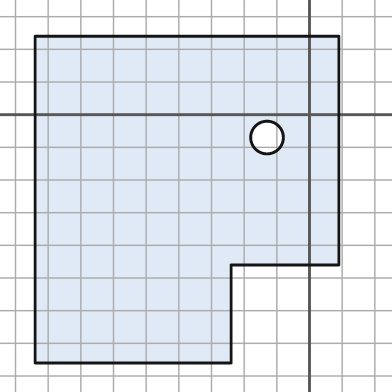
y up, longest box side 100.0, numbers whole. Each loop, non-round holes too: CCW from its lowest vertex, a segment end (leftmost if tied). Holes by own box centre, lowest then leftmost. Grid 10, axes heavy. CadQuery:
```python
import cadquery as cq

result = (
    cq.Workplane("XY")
    .moveTo(-84.0, -76.0)
    .lineTo(-24.0, -76.0)
    .lineTo(-24.0, -46.0)
    .lineTo(9.0, -46.0)
    .lineTo(9.0, 24.0)
    .lineTo(-84.0, 24.0)
    .close()
    .moveTo(-13.0, -7.0)
    .circle(5.0)
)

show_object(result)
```